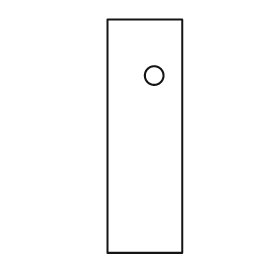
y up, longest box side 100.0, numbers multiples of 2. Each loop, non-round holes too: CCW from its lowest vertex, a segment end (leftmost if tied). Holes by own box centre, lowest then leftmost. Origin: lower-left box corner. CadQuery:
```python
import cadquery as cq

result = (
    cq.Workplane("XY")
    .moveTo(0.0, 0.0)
    .lineTo(32.0, 0.0)
    .lineTo(32.0, 100.0)
    .lineTo(0.0, 100.0)
    .close()
    .moveTo(20.0, 76.0)
    .circle(4.0)
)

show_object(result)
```